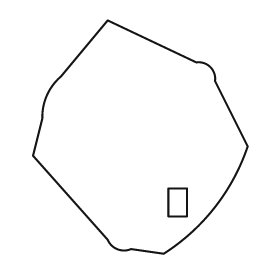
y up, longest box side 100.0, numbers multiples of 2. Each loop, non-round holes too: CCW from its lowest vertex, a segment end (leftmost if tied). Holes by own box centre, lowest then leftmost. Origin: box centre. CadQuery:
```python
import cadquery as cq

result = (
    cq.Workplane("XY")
    .moveTo(10.0, -50.0)
    .threePointArc((32.0, -30.0), (46.0, -4.0))
    .lineTo(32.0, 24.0)
    .threePointArc((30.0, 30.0), (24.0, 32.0))
    .lineTo(-14.0, 50.0)
    .lineTo(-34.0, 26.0)
    .threePointArc((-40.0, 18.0), (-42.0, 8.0))
    .lineTo(-46.0, -8.0)
    .lineTo(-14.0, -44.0)
    .threePointArc((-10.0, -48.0), (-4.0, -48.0))
    .close()
    .moveTo(12.0, -34.0)
    .lineTo(20.0, -34.0)
    .lineTo(20.0, -22.0)
    .lineTo(12.0, -22.0)
    .close()
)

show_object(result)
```